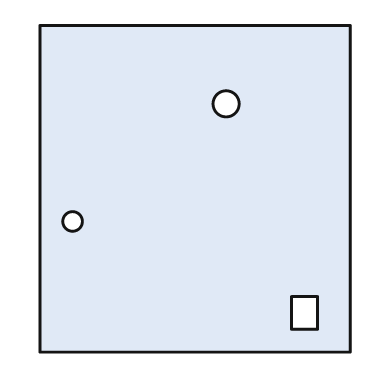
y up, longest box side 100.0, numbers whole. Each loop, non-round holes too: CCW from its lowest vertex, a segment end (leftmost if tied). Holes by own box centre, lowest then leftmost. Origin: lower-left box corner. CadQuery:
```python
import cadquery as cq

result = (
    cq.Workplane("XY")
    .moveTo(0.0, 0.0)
    .lineTo(95.0, 0.0)
    .lineTo(95.0, 100.0)
    .lineTo(0.0, 100.0)
    .close()
    .moveTo(77.0, 7.0)
    .lineTo(85.0, 7.0)
    .lineTo(85.0, 17.0)
    .lineTo(77.0, 17.0)
    .close()
    .moveTo(10.0, 40.0)
    .circle(3.0)
    .moveTo(57.0, 76.0)
    .circle(4.0)
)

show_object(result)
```